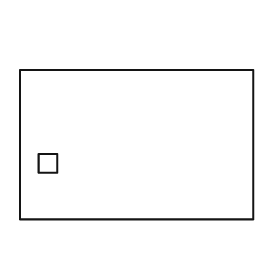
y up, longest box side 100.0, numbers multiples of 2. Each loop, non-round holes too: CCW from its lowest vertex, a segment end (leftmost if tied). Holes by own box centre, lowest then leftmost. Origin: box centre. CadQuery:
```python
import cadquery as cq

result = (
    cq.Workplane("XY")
    .moveTo(-50.0, -32.0)
    .lineTo(50.0, -32.0)
    .lineTo(50.0, 32.0)
    .lineTo(-50.0, 32.0)
    .close()
    .moveTo(-42.0, -12.0)
    .lineTo(-34.0, -12.0)
    .lineTo(-34.0, -4.0)
    .lineTo(-42.0, -4.0)
    .close()
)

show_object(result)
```